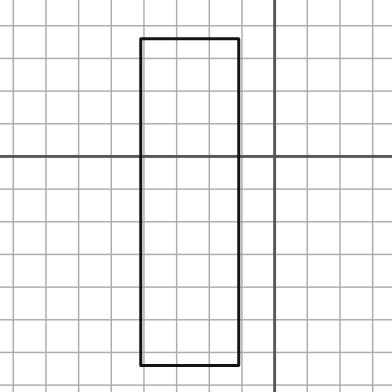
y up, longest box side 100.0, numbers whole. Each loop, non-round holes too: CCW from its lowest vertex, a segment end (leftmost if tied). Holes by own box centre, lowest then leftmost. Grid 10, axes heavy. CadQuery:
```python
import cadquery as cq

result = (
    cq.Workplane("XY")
    .moveTo(-41.0, -64.0)
    .lineTo(-11.0, -64.0)
    .lineTo(-11.0, 36.0)
    .lineTo(-41.0, 36.0)
    .close()
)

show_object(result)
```